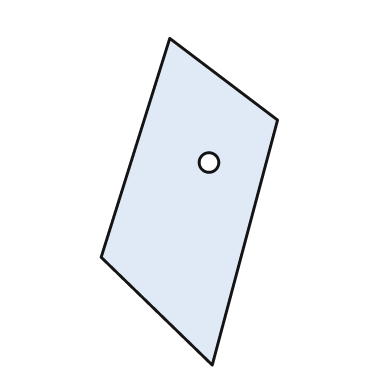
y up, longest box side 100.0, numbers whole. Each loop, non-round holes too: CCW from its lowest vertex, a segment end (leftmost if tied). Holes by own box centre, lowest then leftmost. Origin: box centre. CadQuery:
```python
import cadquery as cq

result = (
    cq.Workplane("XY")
    .moveTo(7.0, -50.0)
    .lineTo(27.0, 25.0)
    .lineTo(-6.0, 50.0)
    .lineTo(-27.0, -17.0)
    .close()
    .moveTo(6.0, 12.0)
    .circle(3.0)
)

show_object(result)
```